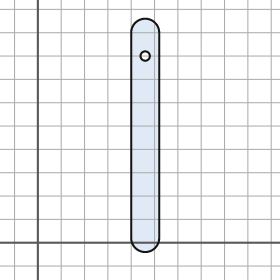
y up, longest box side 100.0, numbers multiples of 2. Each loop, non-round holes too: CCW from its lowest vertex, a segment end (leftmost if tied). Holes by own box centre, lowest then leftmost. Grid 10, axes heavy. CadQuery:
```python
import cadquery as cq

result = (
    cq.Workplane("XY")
    .moveTo(40.0, 2.0)
    .threePointArc((46.0, -4.0), (52.0, 2.0))
    .lineTo(52.0, 90.0)
    .threePointArc((46.0, 96.0), (40.0, 90.0))
    .close()
    .moveTo(46.0, 80.0)
    .circle(2.0)
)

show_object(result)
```